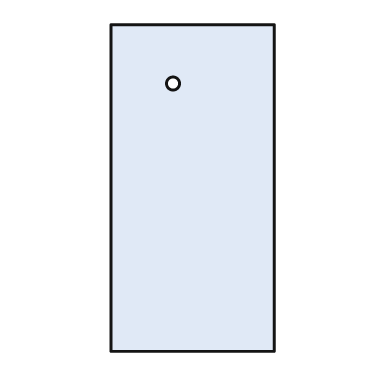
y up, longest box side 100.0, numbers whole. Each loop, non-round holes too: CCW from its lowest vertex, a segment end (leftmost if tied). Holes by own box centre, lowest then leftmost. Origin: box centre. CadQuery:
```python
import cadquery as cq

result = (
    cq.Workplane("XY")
    .moveTo(-25.0, -50.0)
    .lineTo(25.0, -50.0)
    .lineTo(25.0, 50.0)
    .lineTo(-25.0, 50.0)
    .close()
    .moveTo(-6.0, 32.0)
    .circle(2.0)
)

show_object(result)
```